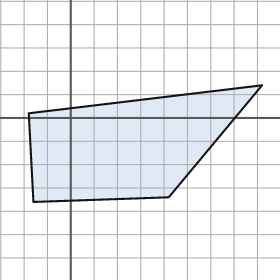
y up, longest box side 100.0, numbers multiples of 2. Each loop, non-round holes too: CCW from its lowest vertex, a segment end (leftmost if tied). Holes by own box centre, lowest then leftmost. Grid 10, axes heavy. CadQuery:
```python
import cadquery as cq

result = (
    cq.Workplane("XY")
    .moveTo(-16.0, -36.0)
    .lineTo(42.0, -34.0)
    .lineTo(82.0, 14.0)
    .lineTo(-18.0, 2.0)
    .close()
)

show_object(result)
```